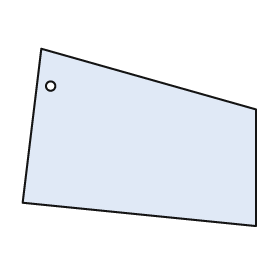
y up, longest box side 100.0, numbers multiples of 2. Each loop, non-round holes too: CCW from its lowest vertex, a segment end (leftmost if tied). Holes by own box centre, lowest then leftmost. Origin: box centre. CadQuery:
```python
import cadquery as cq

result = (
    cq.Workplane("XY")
    .moveTo(50.0, -38.0)
    .lineTo(50.0, 12.0)
    .lineTo(-42.0, 38.0)
    .lineTo(-50.0, -28.0)
    .close()
    .moveTo(-38.0, 22.0)
    .circle(2.0)
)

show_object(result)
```